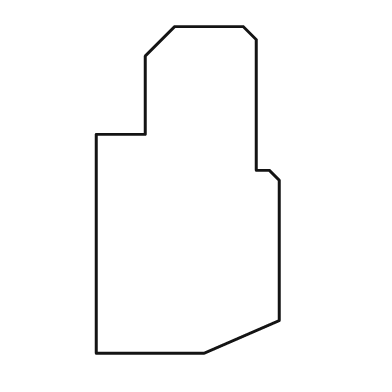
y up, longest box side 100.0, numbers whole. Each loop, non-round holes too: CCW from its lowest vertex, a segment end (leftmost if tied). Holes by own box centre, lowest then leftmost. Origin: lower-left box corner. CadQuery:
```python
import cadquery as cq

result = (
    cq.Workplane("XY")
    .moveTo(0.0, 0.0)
    .lineTo(33.0, 0.0)
    .lineTo(56.0, 10.0)
    .lineTo(56.0, 53.0)
    .lineTo(53.0, 56.0)
    .lineTo(49.0, 56.0)
    .lineTo(49.0, 96.0)
    .lineTo(45.0, 100.0)
    .lineTo(24.0, 100.0)
    .lineTo(15.0, 91.0)
    .lineTo(15.0, 67.0)
    .lineTo(0.0, 67.0)
    .close()
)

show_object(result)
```